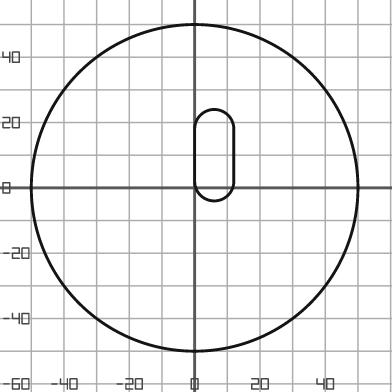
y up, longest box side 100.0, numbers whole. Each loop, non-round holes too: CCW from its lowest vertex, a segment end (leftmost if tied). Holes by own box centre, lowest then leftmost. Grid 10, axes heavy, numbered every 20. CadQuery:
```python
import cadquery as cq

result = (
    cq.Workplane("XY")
    .moveTo(0.0, 0.0)
    .circle(50.0)
    .moveTo(0.0, 2.0)
    .threePointArc((6.0, -4.0), (12.0, 2.0))
    .lineTo(12.0, 18.0)
    .threePointArc((6.0, 24.0), (0.0, 18.0))
    .close()
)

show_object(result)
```